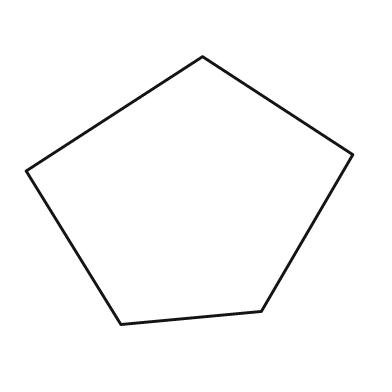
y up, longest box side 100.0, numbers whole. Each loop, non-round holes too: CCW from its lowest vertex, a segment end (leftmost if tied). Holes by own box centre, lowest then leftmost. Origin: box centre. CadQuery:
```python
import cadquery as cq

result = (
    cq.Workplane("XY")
    .moveTo(-21.0, -41.0)
    .lineTo(22.0, -37.0)
    .lineTo(50.0, 11.0)
    .lineTo(4.0, 41.0)
    .lineTo(-50.0, 6.0)
    .close()
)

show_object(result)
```